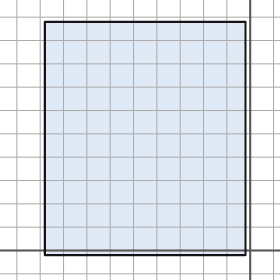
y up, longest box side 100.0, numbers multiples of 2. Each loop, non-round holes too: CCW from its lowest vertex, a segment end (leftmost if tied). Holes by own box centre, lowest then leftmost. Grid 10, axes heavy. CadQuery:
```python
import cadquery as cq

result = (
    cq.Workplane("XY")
    .moveTo(-88.0, -2.0)
    .lineTo(-2.0, -2.0)
    .lineTo(-2.0, 98.0)
    .lineTo(-88.0, 98.0)
    .close()
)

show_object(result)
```